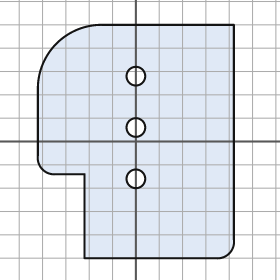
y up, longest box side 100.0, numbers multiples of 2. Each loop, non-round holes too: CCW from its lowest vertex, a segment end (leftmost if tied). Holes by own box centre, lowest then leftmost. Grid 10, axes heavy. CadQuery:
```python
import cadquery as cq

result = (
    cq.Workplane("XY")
    .moveTo(-22.0, -50.0)
    .lineTo(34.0, -50.0)
    .threePointArc((40.0, -48.0), (42.0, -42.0))
    .lineTo(42.0, 50.0)
    .lineTo(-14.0, 50.0)
    .threePointArc((-34.0, 42.0), (-42.0, 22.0))
    .lineTo(-42.0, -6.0)
    .threePointArc((-40.0, -12.0), (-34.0, -14.0))
    .lineTo(-22.0, -14.0)
    .close()
    .moveTo(0.0, -16.0)
    .circle(4.0)
    .moveTo(0.0, 6.0)
    .circle(4.0)
    .moveTo(0.0, 28.0)
    .circle(4.0)
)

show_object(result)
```